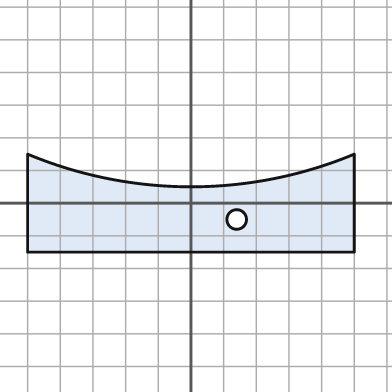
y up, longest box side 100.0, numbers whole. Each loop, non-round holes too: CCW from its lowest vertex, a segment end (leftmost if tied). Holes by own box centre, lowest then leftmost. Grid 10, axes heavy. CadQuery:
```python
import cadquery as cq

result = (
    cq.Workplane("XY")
    .moveTo(-50.0, -15.0)
    .lineTo(50.0, -15.0)
    .lineTo(50.0, 15.0)
    .threePointArc((0.0, 5.0), (-50.0, 15.0))
    .close()
    .moveTo(14.0, -5.0)
    .circle(3.0)
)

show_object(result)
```